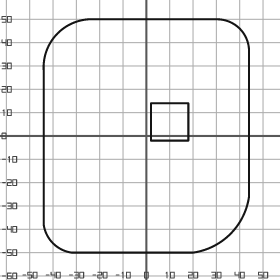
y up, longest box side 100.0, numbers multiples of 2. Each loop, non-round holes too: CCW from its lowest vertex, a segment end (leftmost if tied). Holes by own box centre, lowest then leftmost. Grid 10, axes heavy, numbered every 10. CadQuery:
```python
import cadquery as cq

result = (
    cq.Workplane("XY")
    .moveTo(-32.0, -50.0)
    .lineTo(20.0, -50.0)
    .threePointArc((36.0, -42.0), (44.0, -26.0))
    .lineTo(44.0, 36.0)
    .threePointArc((40.0, 46.0), (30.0, 50.0))
    .lineTo(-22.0, 50.0)
    .threePointArc((-38.0, 44.0), (-44.0, 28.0))
    .lineTo(-44.0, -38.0)
    .threePointArc((-40.0, -46.0), (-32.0, -50.0))
    .close()
    .moveTo(2.0, -2.0)
    .lineTo(18.0, -2.0)
    .lineTo(18.0, 14.0)
    .lineTo(2.0, 14.0)
    .close()
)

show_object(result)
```